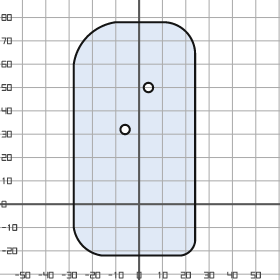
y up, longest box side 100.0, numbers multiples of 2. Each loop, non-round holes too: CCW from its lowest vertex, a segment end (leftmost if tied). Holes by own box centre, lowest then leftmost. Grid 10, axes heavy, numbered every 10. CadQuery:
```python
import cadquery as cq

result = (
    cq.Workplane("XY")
    .moveTo(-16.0, -22.0)
    .lineTo(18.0, -22.0)
    .threePointArc((22.0, -20.0), (24.0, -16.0))
    .lineTo(24.0, 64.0)
    .threePointArc((20.0, 74.0), (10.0, 78.0))
    .lineTo(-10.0, 78.0)
    .threePointArc((-22.0, 72.0), (-28.0, 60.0))
    .lineTo(-28.0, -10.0)
    .threePointArc((-24.0, -18.0), (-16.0, -22.0))
    .close()
    .moveTo(-6.0, 32.0)
    .circle(2.0)
    .moveTo(4.0, 50.0)
    .circle(2.0)
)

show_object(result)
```